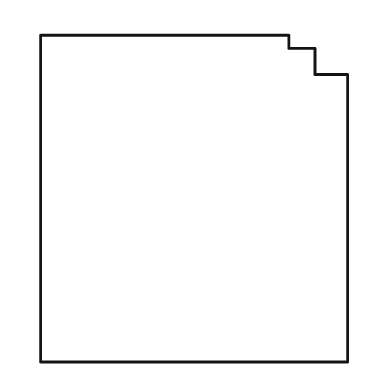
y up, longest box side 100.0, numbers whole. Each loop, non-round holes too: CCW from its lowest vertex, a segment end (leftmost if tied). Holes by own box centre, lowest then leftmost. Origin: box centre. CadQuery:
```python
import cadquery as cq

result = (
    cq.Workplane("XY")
    .moveTo(-47.0, -50.0)
    .lineTo(47.0, -50.0)
    .lineTo(47.0, 38.0)
    .lineTo(37.0, 38.0)
    .lineTo(37.0, 46.0)
    .lineTo(29.0, 46.0)
    .lineTo(29.0, 50.0)
    .lineTo(-47.0, 50.0)
    .close()
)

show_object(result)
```